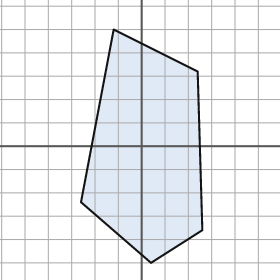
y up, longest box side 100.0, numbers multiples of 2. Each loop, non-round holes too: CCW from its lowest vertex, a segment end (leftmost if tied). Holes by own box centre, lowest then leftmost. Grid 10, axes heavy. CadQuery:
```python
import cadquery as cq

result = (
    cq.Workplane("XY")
    .moveTo(4.0, -50.0)
    .lineTo(26.0, -36.0)
    .lineTo(24.0, 32.0)
    .lineTo(-12.0, 50.0)
    .lineTo(-26.0, -24.0)
    .close()
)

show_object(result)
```